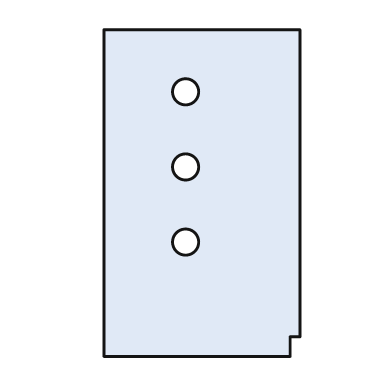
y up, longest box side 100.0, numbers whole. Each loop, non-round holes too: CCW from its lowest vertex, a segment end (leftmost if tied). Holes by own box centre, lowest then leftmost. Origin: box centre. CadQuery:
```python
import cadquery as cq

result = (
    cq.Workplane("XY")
    .moveTo(-30.0, -50.0)
    .lineTo(27.0, -50.0)
    .lineTo(27.0, -44.0)
    .lineTo(30.0, -44.0)
    .lineTo(30.0, 50.0)
    .lineTo(-30.0, 50.0)
    .close()
    .moveTo(-5.0, -15.0)
    .circle(4.0)
    .moveTo(-5.0, 8.0)
    .circle(4.0)
    .moveTo(-5.0, 31.0)
    .circle(4.0)
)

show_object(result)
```